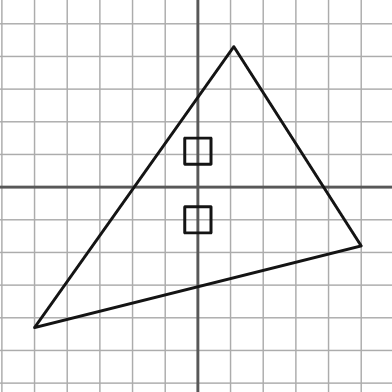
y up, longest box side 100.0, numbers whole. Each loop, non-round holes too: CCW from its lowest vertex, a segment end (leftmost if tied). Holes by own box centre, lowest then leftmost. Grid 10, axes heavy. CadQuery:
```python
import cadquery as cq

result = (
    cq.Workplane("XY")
    .moveTo(-50.0, -43.0)
    .lineTo(50.0, -18.0)
    .lineTo(11.0, 43.0)
    .close()
    .moveTo(-4.0, -14.0)
    .lineTo(4.0, -14.0)
    .lineTo(4.0, -6.0)
    .lineTo(-4.0, -6.0)
    .close()
    .moveTo(-4.0, 7.0)
    .lineTo(4.0, 7.0)
    .lineTo(4.0, 15.0)
    .lineTo(-4.0, 15.0)
    .close()
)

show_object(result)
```